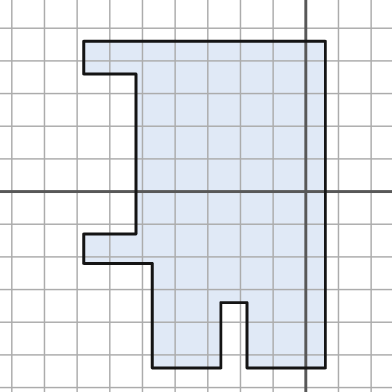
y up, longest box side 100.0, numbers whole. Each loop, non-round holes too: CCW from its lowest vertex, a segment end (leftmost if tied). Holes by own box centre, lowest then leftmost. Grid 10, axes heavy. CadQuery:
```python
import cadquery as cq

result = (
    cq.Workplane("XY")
    .moveTo(-47.0, -54.0)
    .lineTo(-26.0, -54.0)
    .lineTo(-26.0, -34.0)
    .lineTo(-18.0, -34.0)
    .lineTo(-18.0, -54.0)
    .lineTo(6.0, -54.0)
    .lineTo(6.0, 46.0)
    .lineTo(-68.0, 46.0)
    .lineTo(-68.0, 36.0)
    .lineTo(-52.0, 36.0)
    .lineTo(-52.0, -13.0)
    .lineTo(-68.0, -13.0)
    .lineTo(-68.0, -22.0)
    .lineTo(-47.0, -22.0)
    .close()
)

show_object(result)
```